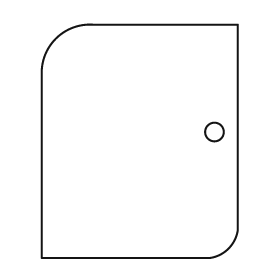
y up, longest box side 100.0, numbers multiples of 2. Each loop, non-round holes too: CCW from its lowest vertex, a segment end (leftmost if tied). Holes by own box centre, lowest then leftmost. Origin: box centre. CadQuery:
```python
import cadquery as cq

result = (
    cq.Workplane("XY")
    .moveTo(-42.0, -50.0)
    .lineTo(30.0, -50.0)
    .threePointArc((38.0, -46.0), (42.0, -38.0))
    .lineTo(42.0, 50.0)
    .lineTo(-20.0, 50.0)
    .threePointArc((-36.0, 44.0), (-42.0, 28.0))
    .close()
    .moveTo(32.0, 4.0)
    .circle(4.0)
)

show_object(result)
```